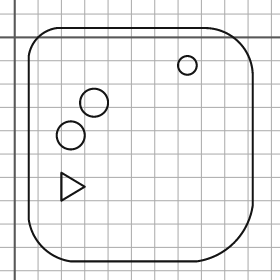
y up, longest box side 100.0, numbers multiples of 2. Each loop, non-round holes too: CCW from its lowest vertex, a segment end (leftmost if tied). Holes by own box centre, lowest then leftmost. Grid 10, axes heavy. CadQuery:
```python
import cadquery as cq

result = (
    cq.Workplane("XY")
    .moveTo(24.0, -96.0)
    .lineTo(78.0, -96.0)
    .threePointArc((94.0, -88.0), (102.0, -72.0))
    .lineTo(102.0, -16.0)
    .threePointArc((96.0, -2.0), (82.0, 4.0))
    .lineTo(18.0, 4.0)
    .threePointArc((10.0, 0.0), (6.0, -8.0))
    .lineTo(6.0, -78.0)
    .threePointArc((12.0, -90.0), (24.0, -96.0))
    .close()
    .moveTo(20.0, -70.0)
    .lineTo(30.0, -64.0)
    .lineTo(20.0, -58.0)
    .close()
    .moveTo(24.0, -42.0)
    .circle(6.0)
    .moveTo(34.0, -28.0)
    .circle(6.0)
    .moveTo(74.0, -12.0)
    .circle(4.0)
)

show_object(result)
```